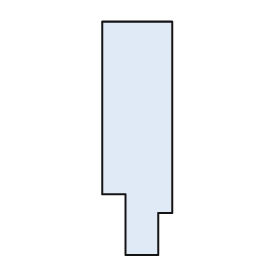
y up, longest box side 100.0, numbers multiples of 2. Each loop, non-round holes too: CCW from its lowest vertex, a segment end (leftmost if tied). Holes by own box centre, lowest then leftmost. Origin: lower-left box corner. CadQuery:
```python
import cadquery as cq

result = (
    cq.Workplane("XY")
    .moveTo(10.0, 0.0)
    .lineTo(24.0, 0.0)
    .lineTo(24.0, 18.0)
    .lineTo(30.0, 18.0)
    .lineTo(30.0, 100.0)
    .lineTo(0.0, 100.0)
    .lineTo(0.0, 26.0)
    .lineTo(10.0, 26.0)
    .close()
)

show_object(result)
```